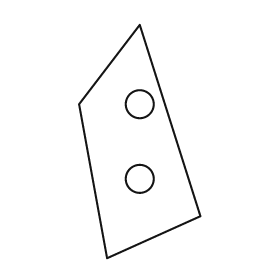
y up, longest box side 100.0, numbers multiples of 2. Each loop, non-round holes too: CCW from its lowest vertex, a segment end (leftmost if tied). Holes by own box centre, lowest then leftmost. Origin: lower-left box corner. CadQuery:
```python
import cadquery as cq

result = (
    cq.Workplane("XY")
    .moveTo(12.0, 0.0)
    .lineTo(52.0, 18.0)
    .lineTo(26.0, 100.0)
    .lineTo(0.0, 66.0)
    .close()
    .moveTo(26.0, 34.0)
    .circle(6.0)
    .moveTo(26.0, 66.0)
    .circle(6.0)
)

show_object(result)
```